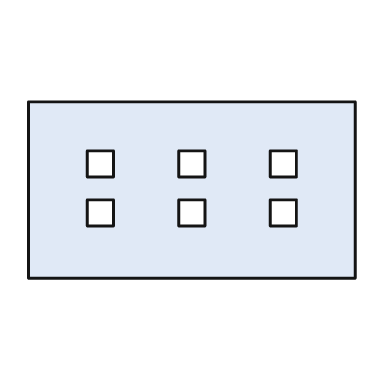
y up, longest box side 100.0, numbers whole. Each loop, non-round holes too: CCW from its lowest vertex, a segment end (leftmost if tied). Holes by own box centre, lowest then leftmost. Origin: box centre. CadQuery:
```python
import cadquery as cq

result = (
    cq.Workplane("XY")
    .moveTo(-50.0, -27.0)
    .lineTo(50.0, -27.0)
    .lineTo(50.0, 27.0)
    .lineTo(-50.0, 27.0)
    .close()
    .moveTo(-32.0, -11.0)
    .lineTo(-24.0, -11.0)
    .lineTo(-24.0, -3.0)
    .lineTo(-32.0, -3.0)
    .close()
    .moveTo(-4.0, -11.0)
    .lineTo(4.0, -11.0)
    .lineTo(4.0, -3.0)
    .lineTo(-4.0, -3.0)
    .close()
    .moveTo(24.0, -11.0)
    .lineTo(32.0, -11.0)
    .lineTo(32.0, -3.0)
    .lineTo(24.0, -3.0)
    .close()
    .moveTo(-32.0, 4.0)
    .lineTo(-24.0, 4.0)
    .lineTo(-24.0, 12.0)
    .lineTo(-32.0, 12.0)
    .close()
    .moveTo(-4.0, 4.0)
    .lineTo(4.0, 4.0)
    .lineTo(4.0, 12.0)
    .lineTo(-4.0, 12.0)
    .close()
    .moveTo(24.0, 4.0)
    .lineTo(32.0, 4.0)
    .lineTo(32.0, 12.0)
    .lineTo(24.0, 12.0)
    .close()
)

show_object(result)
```